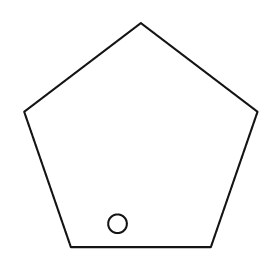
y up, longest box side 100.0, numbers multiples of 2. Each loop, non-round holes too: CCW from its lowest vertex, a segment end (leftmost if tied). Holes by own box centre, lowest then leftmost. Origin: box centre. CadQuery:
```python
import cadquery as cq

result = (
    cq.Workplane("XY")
    .moveTo(-30.0, -48.0)
    .lineTo(30.0, -48.0)
    .lineTo(50.0, 10.0)
    .lineTo(0.0, 48.0)
    .lineTo(-50.0, 10.0)
    .close()
    .moveTo(-10.0, -38.0)
    .circle(4.0)
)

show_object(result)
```